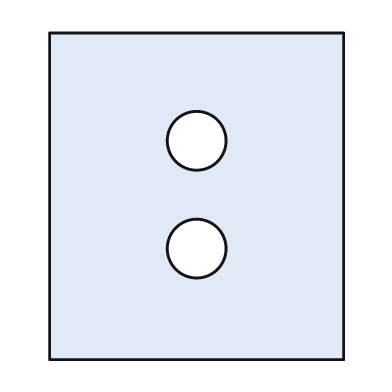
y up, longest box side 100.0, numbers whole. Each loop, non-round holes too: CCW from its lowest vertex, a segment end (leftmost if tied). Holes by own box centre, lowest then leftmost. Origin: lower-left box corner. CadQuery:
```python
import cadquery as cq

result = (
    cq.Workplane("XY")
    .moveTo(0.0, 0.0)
    .lineTo(90.0, 0.0)
    .lineTo(90.0, 100.0)
    .lineTo(0.0, 100.0)
    .close()
    .moveTo(45.0, 34.0)
    .circle(9.0)
    .moveTo(45.0, 67.0)
    .circle(9.0)
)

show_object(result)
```